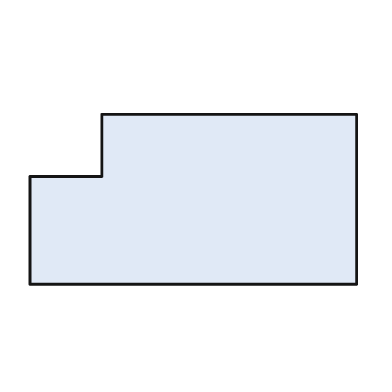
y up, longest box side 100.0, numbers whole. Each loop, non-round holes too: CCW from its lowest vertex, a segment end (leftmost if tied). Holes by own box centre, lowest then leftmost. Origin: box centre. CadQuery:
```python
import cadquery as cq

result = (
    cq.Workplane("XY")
    .moveTo(-50.0, -26.0)
    .lineTo(50.0, -26.0)
    .lineTo(50.0, 26.0)
    .lineTo(-28.0, 26.0)
    .lineTo(-28.0, 7.0)
    .lineTo(-50.0, 7.0)
    .close()
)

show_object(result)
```